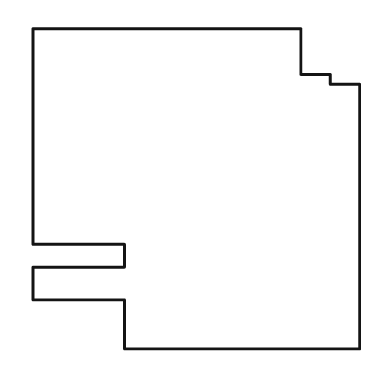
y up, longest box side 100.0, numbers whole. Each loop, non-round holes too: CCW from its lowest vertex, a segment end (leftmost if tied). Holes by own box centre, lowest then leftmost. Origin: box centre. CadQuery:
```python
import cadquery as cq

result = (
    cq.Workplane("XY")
    .moveTo(-22.0, -49.0)
    .lineTo(50.0, -49.0)
    .lineTo(50.0, 32.0)
    .lineTo(41.0, 32.0)
    .lineTo(41.0, 35.0)
    .lineTo(32.0, 35.0)
    .lineTo(32.0, 49.0)
    .lineTo(-50.0, 49.0)
    .lineTo(-50.0, -17.0)
    .lineTo(-22.0, -17.0)
    .lineTo(-22.0, -24.0)
    .lineTo(-50.0, -24.0)
    .lineTo(-50.0, -34.0)
    .lineTo(-22.0, -34.0)
    .close()
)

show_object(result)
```